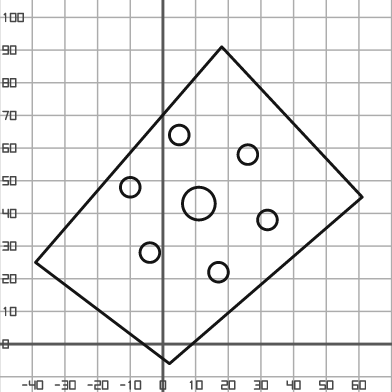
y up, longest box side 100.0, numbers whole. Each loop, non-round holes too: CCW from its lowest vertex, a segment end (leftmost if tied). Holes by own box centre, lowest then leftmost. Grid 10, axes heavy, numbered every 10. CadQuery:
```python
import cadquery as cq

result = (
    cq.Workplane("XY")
    .moveTo(2.0, -6.0)
    .lineTo(61.0, 45.0)
    .lineTo(18.0, 91.0)
    .lineTo(-39.0, 25.0)
    .close()
    .moveTo(17.0, 22.0)
    .circle(3.0)
    .moveTo(-4.0, 28.0)
    .circle(3.0)
    .moveTo(32.0, 38.0)
    .circle(3.0)
    .moveTo(11.0, 43.0)
    .circle(5.0)
    .moveTo(-10.0, 48.0)
    .circle(3.0)
    .moveTo(26.0, 58.0)
    .circle(3.0)
    .moveTo(5.0, 64.0)
    .circle(3.0)
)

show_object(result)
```